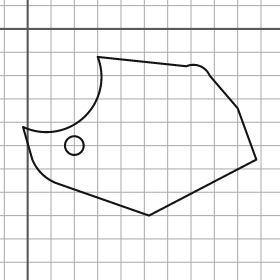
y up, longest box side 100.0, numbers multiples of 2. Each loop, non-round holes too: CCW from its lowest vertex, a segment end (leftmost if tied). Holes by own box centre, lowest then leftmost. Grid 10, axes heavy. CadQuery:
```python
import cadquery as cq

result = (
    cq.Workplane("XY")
    .moveTo(52.0, -80.0)
    .lineTo(98.0, -56.0)
    .lineTo(90.0, -34.0)
    .lineTo(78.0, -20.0)
    .threePointArc((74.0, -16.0), (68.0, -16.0))
    .lineTo(30.0, -12.0)
    .threePointArc((24.0, -38.0), (-2.0, -42.0))
    .lineTo(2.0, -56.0)
    .threePointArc((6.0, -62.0), (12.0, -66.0))
    .close()
    .moveTo(20.0, -50.0)
    .circle(4.0)
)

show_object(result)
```